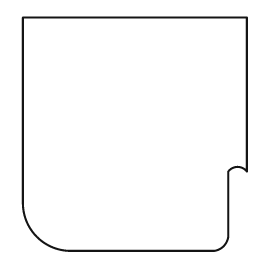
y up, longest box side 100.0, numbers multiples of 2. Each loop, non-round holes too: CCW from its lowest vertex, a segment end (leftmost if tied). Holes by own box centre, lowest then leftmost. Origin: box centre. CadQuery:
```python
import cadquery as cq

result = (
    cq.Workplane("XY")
    .moveTo(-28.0, -50.0)
    .lineTo(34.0, -50.0)
    .threePointArc((38.0, -48.0), (40.0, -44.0))
    .lineTo(40.0, -16.0)
    .threePointArc((44.0, -14.0), (48.0, -16.0))
    .lineTo(48.0, 50.0)
    .lineTo(-48.0, 50.0)
    .lineTo(-48.0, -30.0)
    .threePointArc((-42.0, -44.0), (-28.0, -50.0))
    .close()
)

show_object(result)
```